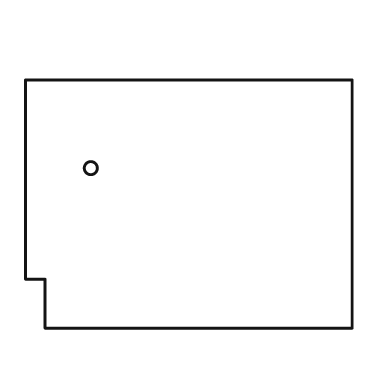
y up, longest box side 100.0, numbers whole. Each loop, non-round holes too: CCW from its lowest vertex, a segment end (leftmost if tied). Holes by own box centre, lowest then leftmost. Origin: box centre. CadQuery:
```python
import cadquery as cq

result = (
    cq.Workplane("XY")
    .moveTo(-44.0, -38.0)
    .lineTo(50.0, -38.0)
    .lineTo(50.0, 38.0)
    .lineTo(-50.0, 38.0)
    .lineTo(-50.0, -23.0)
    .lineTo(-44.0, -23.0)
    .close()
    .moveTo(-30.0, 11.0)
    .circle(2.0)
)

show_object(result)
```